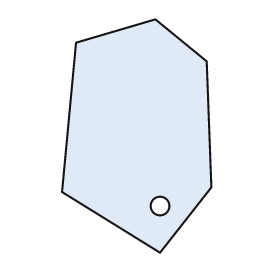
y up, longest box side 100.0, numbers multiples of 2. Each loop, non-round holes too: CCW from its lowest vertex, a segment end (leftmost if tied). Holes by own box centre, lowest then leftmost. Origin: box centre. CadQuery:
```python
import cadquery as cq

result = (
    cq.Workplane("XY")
    .moveTo(10.0, -50.0)
    .lineTo(32.0, -22.0)
    .lineTo(30.0, 32.0)
    .lineTo(8.0, 50.0)
    .lineTo(-26.0, 40.0)
    .lineTo(-32.0, -24.0)
    .close()
    .moveTo(10.0, -30.0)
    .circle(4.0)
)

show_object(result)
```